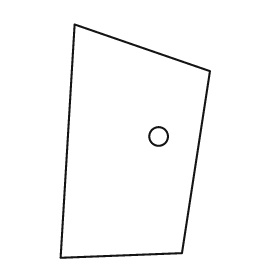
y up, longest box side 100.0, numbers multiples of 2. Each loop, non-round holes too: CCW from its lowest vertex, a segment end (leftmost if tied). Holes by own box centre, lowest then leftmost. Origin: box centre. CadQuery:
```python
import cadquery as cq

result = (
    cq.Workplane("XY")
    .moveTo(-32.0, -50.0)
    .lineTo(20.0, -48.0)
    .lineTo(32.0, 30.0)
    .lineTo(-26.0, 50.0)
    .close()
    .moveTo(10.0, 2.0)
    .circle(4.0)
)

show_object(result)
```